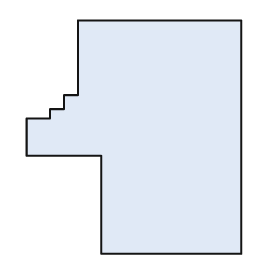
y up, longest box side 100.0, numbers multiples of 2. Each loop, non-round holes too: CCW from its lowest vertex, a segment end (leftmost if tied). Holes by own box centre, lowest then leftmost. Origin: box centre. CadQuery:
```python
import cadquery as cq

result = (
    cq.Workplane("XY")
    .moveTo(-14.0, -50.0)
    .lineTo(46.0, -50.0)
    .lineTo(46.0, 50.0)
    .lineTo(-24.0, 50.0)
    .lineTo(-24.0, 18.0)
    .lineTo(-30.0, 18.0)
    .lineTo(-30.0, 12.0)
    .lineTo(-36.0, 12.0)
    .lineTo(-36.0, 8.0)
    .lineTo(-46.0, 8.0)
    .lineTo(-46.0, -8.0)
    .lineTo(-14.0, -8.0)
    .close()
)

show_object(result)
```